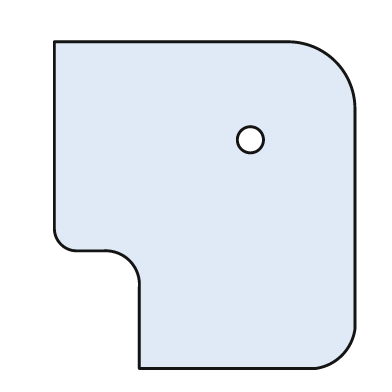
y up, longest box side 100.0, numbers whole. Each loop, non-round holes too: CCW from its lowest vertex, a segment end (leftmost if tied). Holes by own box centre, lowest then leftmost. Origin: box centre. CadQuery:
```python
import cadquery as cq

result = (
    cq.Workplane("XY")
    .moveTo(-20.0, -50.0)
    .lineTo(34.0, -50.0)
    .threePointArc((42.0, -46.0), (46.0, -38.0))
    .lineTo(46.0, 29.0)
    .threePointArc((40.0, 44.0), (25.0, 50.0))
    .lineTo(-46.0, 50.0)
    .lineTo(-46.0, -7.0)
    .threePointArc((-44.0, -12.0), (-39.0, -14.0))
    .lineTo(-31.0, -14.0)
    .threePointArc((-23.0, -17.0), (-20.0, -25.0))
    .close()
    .moveTo(14.0, 20.0)
    .circle(4.0)
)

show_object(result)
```